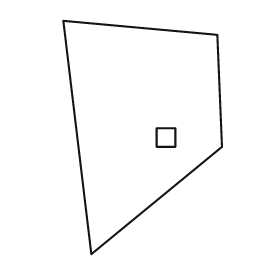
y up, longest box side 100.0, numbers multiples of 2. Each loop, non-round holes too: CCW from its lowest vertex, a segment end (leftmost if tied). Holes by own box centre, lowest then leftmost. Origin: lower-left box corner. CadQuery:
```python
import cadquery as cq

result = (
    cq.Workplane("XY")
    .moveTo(12.0, 0.0)
    .lineTo(68.0, 46.0)
    .lineTo(66.0, 94.0)
    .lineTo(0.0, 100.0)
    .close()
    .moveTo(40.0, 46.0)
    .lineTo(48.0, 46.0)
    .lineTo(48.0, 54.0)
    .lineTo(40.0, 54.0)
    .close()
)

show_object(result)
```